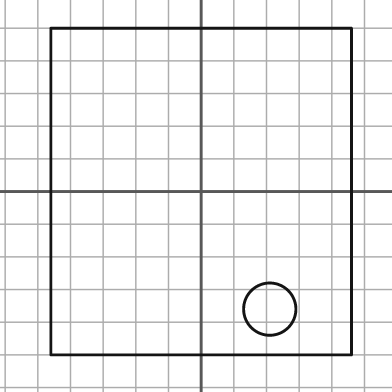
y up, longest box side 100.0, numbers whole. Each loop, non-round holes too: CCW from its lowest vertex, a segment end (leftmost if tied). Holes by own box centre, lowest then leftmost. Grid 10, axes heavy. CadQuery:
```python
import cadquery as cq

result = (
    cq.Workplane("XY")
    .moveTo(-46.0, -50.0)
    .lineTo(46.0, -50.0)
    .lineTo(46.0, 50.0)
    .lineTo(-46.0, 50.0)
    .close()
    .moveTo(21.0, -36.0)
    .circle(8.0)
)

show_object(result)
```